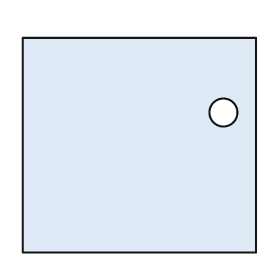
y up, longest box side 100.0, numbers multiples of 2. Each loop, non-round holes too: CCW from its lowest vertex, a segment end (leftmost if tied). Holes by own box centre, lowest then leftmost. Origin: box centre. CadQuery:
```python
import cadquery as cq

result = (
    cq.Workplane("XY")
    .moveTo(-50.0, -46.0)
    .lineTo(50.0, -46.0)
    .lineTo(50.0, 46.0)
    .lineTo(-50.0, 46.0)
    .close()
    .moveTo(36.0, 14.0)
    .circle(6.0)
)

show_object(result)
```